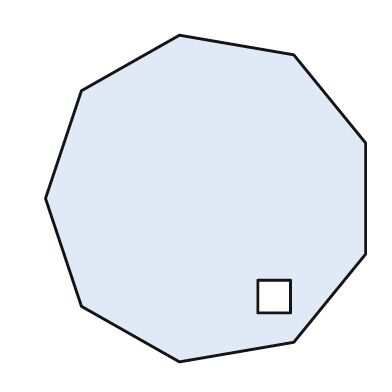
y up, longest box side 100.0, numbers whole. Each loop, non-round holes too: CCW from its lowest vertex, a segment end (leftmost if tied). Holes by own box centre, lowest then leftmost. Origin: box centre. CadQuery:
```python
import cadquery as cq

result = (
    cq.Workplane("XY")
    .moveTo(-8.0, -50.0)
    .lineTo(27.0, -44.0)
    .lineTo(49.0, -17.0)
    .lineTo(49.0, 17.0)
    .lineTo(27.0, 44.0)
    .lineTo(-8.0, 50.0)
    .lineTo(-38.0, 33.0)
    .lineTo(-49.0, 0.0)
    .lineTo(-38.0, -33.0)
    .close()
    .moveTo(16.0, -35.0)
    .lineTo(26.0, -35.0)
    .lineTo(26.0, -25.0)
    .lineTo(16.0, -25.0)
    .close()
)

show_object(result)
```